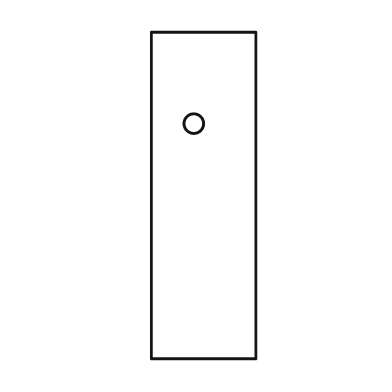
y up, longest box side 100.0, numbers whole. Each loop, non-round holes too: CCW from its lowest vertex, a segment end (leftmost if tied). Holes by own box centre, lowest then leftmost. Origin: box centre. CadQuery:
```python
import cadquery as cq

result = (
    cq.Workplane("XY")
    .moveTo(-16.0, -50.0)
    .lineTo(16.0, -50.0)
    .lineTo(16.0, 50.0)
    .lineTo(-16.0, 50.0)
    .close()
    .moveTo(-3.0, 22.0)
    .circle(3.0)
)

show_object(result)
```